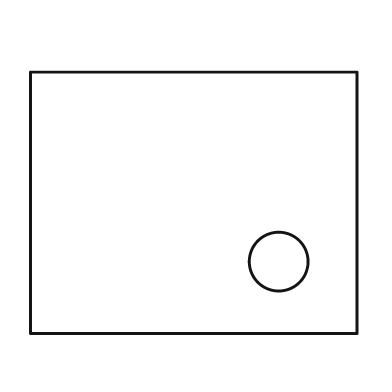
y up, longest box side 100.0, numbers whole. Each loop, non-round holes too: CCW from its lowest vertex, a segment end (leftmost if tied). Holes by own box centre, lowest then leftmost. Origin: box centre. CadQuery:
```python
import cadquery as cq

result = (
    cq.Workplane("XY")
    .moveTo(-50.0, -40.0)
    .lineTo(50.0, -40.0)
    .lineTo(50.0, 40.0)
    .lineTo(-50.0, 40.0)
    .close()
    .moveTo(26.0, -18.0)
    .circle(9.0)
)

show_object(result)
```